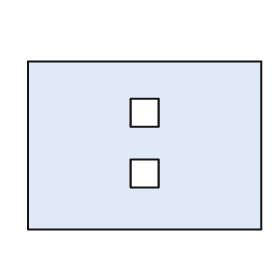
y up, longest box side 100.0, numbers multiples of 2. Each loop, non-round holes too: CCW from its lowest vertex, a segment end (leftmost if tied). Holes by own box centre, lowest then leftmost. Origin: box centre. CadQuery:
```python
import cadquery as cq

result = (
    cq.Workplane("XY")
    .moveTo(-50.0, -36.0)
    .lineTo(50.0, -36.0)
    .lineTo(50.0, 36.0)
    .lineTo(-50.0, 36.0)
    .close()
    .moveTo(-6.0, -18.0)
    .lineTo(6.0, -18.0)
    .lineTo(6.0, -6.0)
    .lineTo(-6.0, -6.0)
    .close()
    .moveTo(-6.0, 8.0)
    .lineTo(6.0, 8.0)
    .lineTo(6.0, 20.0)
    .lineTo(-6.0, 20.0)
    .close()
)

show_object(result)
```